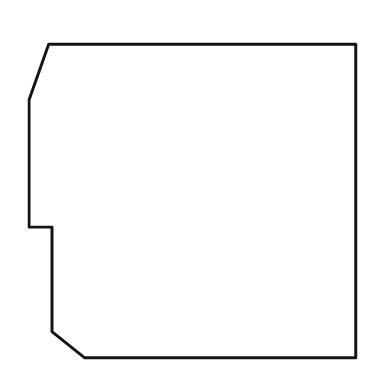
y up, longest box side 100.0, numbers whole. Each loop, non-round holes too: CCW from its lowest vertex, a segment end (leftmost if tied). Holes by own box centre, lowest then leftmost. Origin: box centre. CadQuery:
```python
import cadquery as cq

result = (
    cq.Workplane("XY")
    .moveTo(-33.0, -48.0)
    .lineTo(50.0, -48.0)
    .lineTo(50.0, 48.0)
    .lineTo(-44.0, 48.0)
    .lineTo(-50.0, 31.0)
    .lineTo(-50.0, -8.0)
    .lineTo(-43.0, -8.0)
    .lineTo(-43.0, -40.0)
    .close()
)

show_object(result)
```